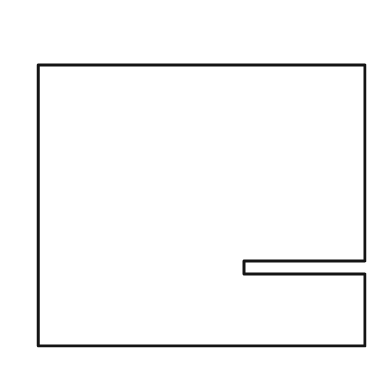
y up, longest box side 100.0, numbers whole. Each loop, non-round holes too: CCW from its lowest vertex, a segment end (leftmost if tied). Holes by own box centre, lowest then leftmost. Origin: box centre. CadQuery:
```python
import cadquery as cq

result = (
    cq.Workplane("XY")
    .moveTo(-50.0, -43.0)
    .lineTo(50.0, -43.0)
    .lineTo(50.0, -21.0)
    .lineTo(13.0, -21.0)
    .lineTo(13.0, -17.0)
    .lineTo(50.0, -17.0)
    .lineTo(50.0, 43.0)
    .lineTo(-50.0, 43.0)
    .close()
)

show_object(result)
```